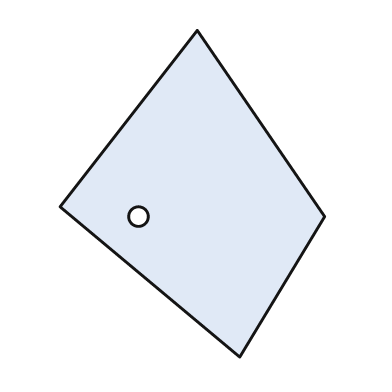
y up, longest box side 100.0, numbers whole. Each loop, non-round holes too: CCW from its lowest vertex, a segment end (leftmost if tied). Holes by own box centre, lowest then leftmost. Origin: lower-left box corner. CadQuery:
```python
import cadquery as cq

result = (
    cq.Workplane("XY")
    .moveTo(55.0, 0.0)
    .lineTo(81.0, 43.0)
    .lineTo(42.0, 100.0)
    .lineTo(0.0, 46.0)
    .close()
    .moveTo(24.0, 43.0)
    .circle(3.0)
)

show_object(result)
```